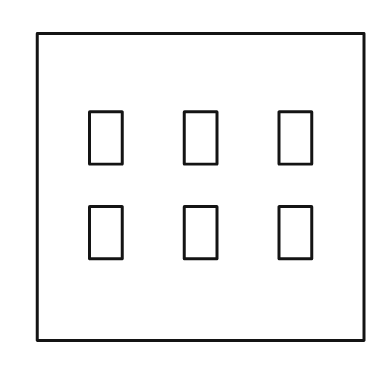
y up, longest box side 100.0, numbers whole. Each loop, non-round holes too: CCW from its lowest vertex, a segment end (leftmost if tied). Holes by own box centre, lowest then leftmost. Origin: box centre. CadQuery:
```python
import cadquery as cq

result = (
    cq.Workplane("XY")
    .moveTo(-50.0, -47.0)
    .lineTo(50.0, -47.0)
    .lineTo(50.0, 47.0)
    .lineTo(-50.0, 47.0)
    .close()
    .moveTo(-34.0, -22.0)
    .lineTo(-24.0, -22.0)
    .lineTo(-24.0, -6.0)
    .lineTo(-34.0, -6.0)
    .close()
    .moveTo(-5.0, -22.0)
    .lineTo(5.0, -22.0)
    .lineTo(5.0, -6.0)
    .lineTo(-5.0, -6.0)
    .close()
    .moveTo(24.0, -22.0)
    .lineTo(34.0, -22.0)
    .lineTo(34.0, -6.0)
    .lineTo(24.0, -6.0)
    .close()
    .moveTo(-34.0, 7.0)
    .lineTo(-24.0, 7.0)
    .lineTo(-24.0, 23.0)
    .lineTo(-34.0, 23.0)
    .close()
    .moveTo(-5.0, 7.0)
    .lineTo(5.0, 7.0)
    .lineTo(5.0, 23.0)
    .lineTo(-5.0, 23.0)
    .close()
    .moveTo(24.0, 7.0)
    .lineTo(34.0, 7.0)
    .lineTo(34.0, 23.0)
    .lineTo(24.0, 23.0)
    .close()
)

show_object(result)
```